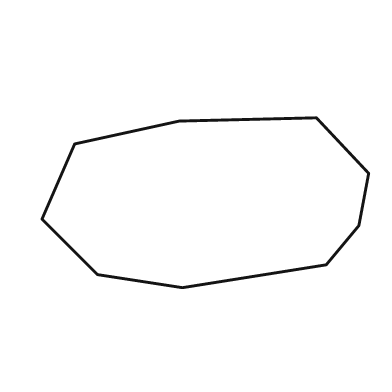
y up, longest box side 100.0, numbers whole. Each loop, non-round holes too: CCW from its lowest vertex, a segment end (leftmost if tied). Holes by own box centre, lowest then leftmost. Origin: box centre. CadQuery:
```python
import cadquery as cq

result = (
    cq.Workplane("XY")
    .moveTo(-7.0, -26.0)
    .lineTo(37.0, -19.0)
    .lineTo(47.0, -7.0)
    .lineTo(50.0, 9.0)
    .lineTo(34.0, 26.0)
    .lineTo(-8.0, 25.0)
    .lineTo(-40.0, 18.0)
    .lineTo(-50.0, -5.0)
    .lineTo(-33.0, -22.0)
    .close()
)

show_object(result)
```